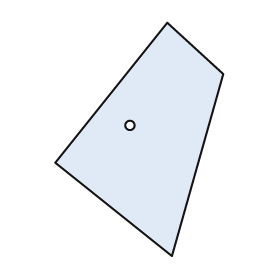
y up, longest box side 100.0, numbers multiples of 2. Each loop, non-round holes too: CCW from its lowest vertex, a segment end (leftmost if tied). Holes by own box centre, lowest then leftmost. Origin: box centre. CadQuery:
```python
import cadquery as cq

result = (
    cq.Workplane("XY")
    .moveTo(14.0, -50.0)
    .lineTo(36.0, 28.0)
    .lineTo(12.0, 50.0)
    .lineTo(-36.0, -10.0)
    .close()
    .moveTo(-4.0, 6.0)
    .circle(2.0)
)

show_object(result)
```